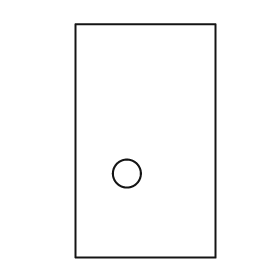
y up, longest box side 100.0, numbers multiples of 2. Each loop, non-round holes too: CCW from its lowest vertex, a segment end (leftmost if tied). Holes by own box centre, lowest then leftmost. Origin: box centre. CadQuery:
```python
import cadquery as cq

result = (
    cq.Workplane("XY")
    .moveTo(-30.0, -50.0)
    .lineTo(30.0, -50.0)
    .lineTo(30.0, 50.0)
    .lineTo(-30.0, 50.0)
    .close()
    .moveTo(-8.0, -14.0)
    .circle(6.0)
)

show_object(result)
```